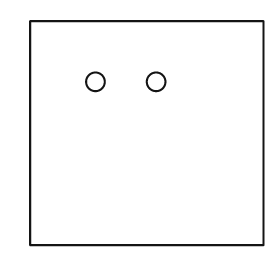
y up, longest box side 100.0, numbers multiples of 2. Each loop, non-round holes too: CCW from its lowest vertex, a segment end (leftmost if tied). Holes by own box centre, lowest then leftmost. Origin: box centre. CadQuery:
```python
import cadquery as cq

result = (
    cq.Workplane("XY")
    .moveTo(-50.0, -48.0)
    .lineTo(50.0, -48.0)
    .lineTo(50.0, 48.0)
    .lineTo(-50.0, 48.0)
    .close()
    .moveTo(-22.0, 22.0)
    .circle(4.0)
    .moveTo(4.0, 22.0)
    .circle(4.0)
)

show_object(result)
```